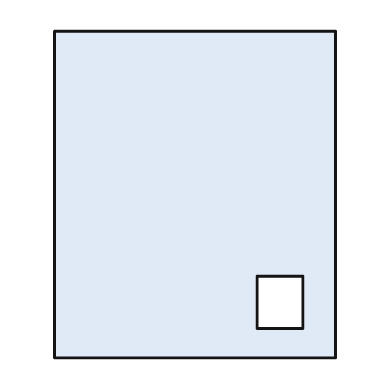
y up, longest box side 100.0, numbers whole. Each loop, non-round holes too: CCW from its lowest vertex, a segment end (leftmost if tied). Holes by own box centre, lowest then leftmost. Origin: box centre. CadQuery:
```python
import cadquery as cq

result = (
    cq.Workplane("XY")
    .moveTo(-43.0, -50.0)
    .lineTo(43.0, -50.0)
    .lineTo(43.0, 50.0)
    .lineTo(-43.0, 50.0)
    .close()
    .moveTo(19.0, -41.0)
    .lineTo(33.0, -41.0)
    .lineTo(33.0, -25.0)
    .lineTo(19.0, -25.0)
    .close()
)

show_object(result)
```